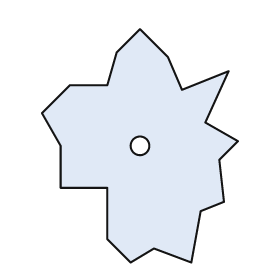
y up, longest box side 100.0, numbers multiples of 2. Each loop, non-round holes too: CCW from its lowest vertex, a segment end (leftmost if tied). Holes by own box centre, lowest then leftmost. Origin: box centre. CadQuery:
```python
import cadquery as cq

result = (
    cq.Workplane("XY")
    .moveTo(-4.0, -50.0)
    .lineTo(6.0, -44.0)
    .lineTo(22.0, -50.0)
    .lineTo(26.0, -28.0)
    .lineTo(36.0, -24.0)
    .lineTo(34.0, -6.0)
    .lineTo(42.0, 2.0)
    .lineTo(28.0, 10.0)
    .lineTo(38.0, 32.0)
    .lineTo(18.0, 24.0)
    .lineTo(12.0, 38.0)
    .lineTo(0.0, 50.0)
    .lineTo(-10.0, 40.0)
    .lineTo(-14.0, 26.0)
    .lineTo(-30.0, 26.0)
    .lineTo(-42.0, 14.0)
    .lineTo(-34.0, 0.0)
    .lineTo(-34.0, -18.0)
    .lineTo(-14.0, -18.0)
    .lineTo(-14.0, -40.0)
    .close()
    .moveTo(0.0, 0.0)
    .circle(4.0)
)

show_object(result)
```